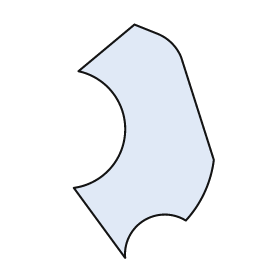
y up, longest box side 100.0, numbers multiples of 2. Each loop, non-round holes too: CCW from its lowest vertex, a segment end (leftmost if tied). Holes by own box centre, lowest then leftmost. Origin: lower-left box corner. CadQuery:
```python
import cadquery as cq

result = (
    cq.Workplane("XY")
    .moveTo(22.0, 0.0)
    .threePointArc((30.0, 16.0), (48.0, 16.0))
    .threePointArc((56.0, 28.0), (60.0, 42.0))
    .lineTo(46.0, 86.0)
    .threePointArc((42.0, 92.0), (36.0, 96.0))
    .lineTo(26.0, 100.0)
    .lineTo(2.0, 80.0)
    .threePointArc((22.0, 54.0), (0.0, 30.0))
    .close()
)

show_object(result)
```